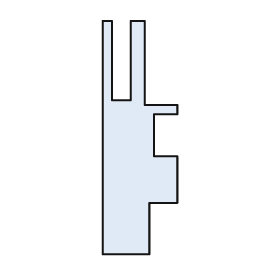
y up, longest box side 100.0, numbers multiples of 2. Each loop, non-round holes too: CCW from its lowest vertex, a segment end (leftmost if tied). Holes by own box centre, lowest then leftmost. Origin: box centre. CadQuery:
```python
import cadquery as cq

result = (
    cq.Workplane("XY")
    .moveTo(-16.0, -50.0)
    .lineTo(4.0, -50.0)
    .lineTo(4.0, -28.0)
    .lineTo(16.0, -28.0)
    .lineTo(16.0, -8.0)
    .lineTo(6.0, -8.0)
    .lineTo(6.0, 10.0)
    .lineTo(16.0, 10.0)
    .lineTo(16.0, 14.0)
    .lineTo(2.0, 14.0)
    .lineTo(2.0, 50.0)
    .lineTo(-4.0, 50.0)
    .lineTo(-4.0, 16.0)
    .lineTo(-12.0, 16.0)
    .lineTo(-12.0, 50.0)
    .lineTo(-16.0, 50.0)
    .close()
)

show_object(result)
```